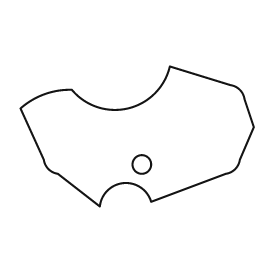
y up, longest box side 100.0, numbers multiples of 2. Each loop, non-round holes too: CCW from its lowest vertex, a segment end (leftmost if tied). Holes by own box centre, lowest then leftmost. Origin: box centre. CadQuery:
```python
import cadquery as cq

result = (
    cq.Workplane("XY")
    .moveTo(-16.0, -30.0)
    .threePointArc((-6.0, -20.0), (6.0, -28.0))
    .lineTo(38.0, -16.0)
    .threePointArc((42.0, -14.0), (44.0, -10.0))
    .lineTo(50.0, 4.0)
    .lineTo(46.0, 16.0)
    .threePointArc((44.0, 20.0), (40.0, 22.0))
    .lineTo(14.0, 30.0)
    .threePointArc((-4.0, 12.0), (-28.0, 20.0))
    .threePointArc((-40.0, 18.0), (-50.0, 12.0))
    .lineTo(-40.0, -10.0)
    .threePointArc((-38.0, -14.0), (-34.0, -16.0))
    .close()
    .moveTo(2.0, -12.0)
    .circle(4.0)
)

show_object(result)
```